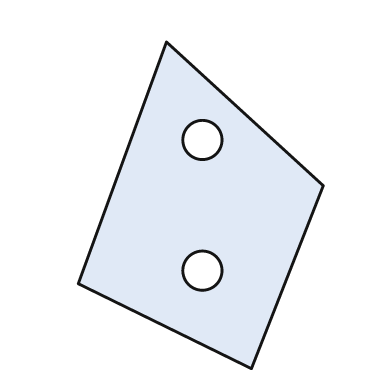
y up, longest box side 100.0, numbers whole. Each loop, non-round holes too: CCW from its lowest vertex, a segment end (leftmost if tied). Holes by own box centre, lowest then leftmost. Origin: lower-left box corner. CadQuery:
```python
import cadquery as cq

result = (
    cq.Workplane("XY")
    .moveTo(53.0, 0.0)
    .lineTo(75.0, 56.0)
    .lineTo(27.0, 100.0)
    .lineTo(0.0, 26.0)
    .close()
    .moveTo(38.0, 30.0)
    .circle(6.0)
    .moveTo(38.0, 70.0)
    .circle(6.0)
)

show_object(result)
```